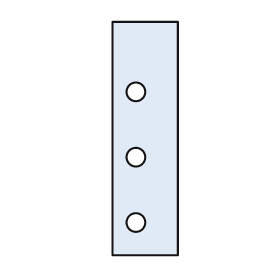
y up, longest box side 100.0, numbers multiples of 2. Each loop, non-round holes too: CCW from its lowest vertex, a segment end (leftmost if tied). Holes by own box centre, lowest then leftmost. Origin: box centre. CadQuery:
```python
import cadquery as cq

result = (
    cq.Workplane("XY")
    .moveTo(-14.0, -50.0)
    .lineTo(14.0, -50.0)
    .lineTo(14.0, 50.0)
    .lineTo(-14.0, 50.0)
    .close()
    .moveTo(-4.0, -36.0)
    .circle(4.0)
    .moveTo(-4.0, -8.0)
    .circle(4.0)
    .moveTo(-4.0, 20.0)
    .circle(4.0)
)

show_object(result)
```